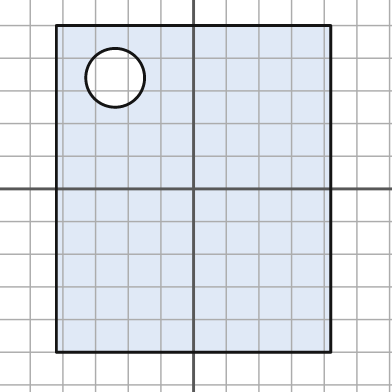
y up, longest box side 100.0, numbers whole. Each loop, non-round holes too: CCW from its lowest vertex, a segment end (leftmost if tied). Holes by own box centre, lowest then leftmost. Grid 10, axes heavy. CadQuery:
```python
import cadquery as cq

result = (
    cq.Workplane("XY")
    .moveTo(-42.0, -50.0)
    .lineTo(42.0, -50.0)
    .lineTo(42.0, 50.0)
    .lineTo(-42.0, 50.0)
    .close()
    .moveTo(-24.0, 34.0)
    .circle(9.0)
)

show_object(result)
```